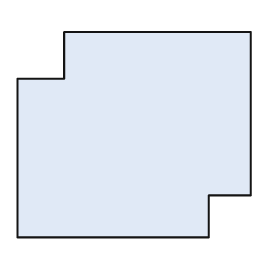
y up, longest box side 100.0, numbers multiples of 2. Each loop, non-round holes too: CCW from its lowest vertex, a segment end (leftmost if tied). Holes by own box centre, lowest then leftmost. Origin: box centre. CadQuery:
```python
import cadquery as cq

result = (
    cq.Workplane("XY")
    .moveTo(-50.0, -44.0)
    .lineTo(32.0, -44.0)
    .lineTo(32.0, -26.0)
    .lineTo(50.0, -26.0)
    .lineTo(50.0, 44.0)
    .lineTo(-30.0, 44.0)
    .lineTo(-30.0, 24.0)
    .lineTo(-50.0, 24.0)
    .close()
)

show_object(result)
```